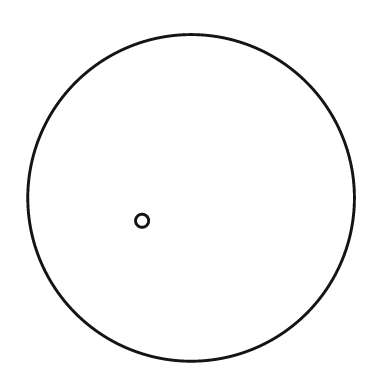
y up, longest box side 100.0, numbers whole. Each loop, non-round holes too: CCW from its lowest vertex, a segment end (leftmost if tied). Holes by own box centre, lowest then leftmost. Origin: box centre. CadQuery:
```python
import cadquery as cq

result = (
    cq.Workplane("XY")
    .moveTo(0.0, 0.0)
    .circle(50.0)
    .moveTo(-15.0, -7.0)
    .circle(2.0)
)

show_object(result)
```